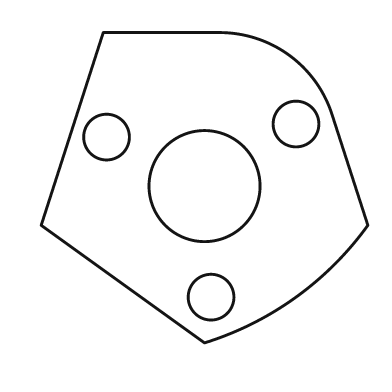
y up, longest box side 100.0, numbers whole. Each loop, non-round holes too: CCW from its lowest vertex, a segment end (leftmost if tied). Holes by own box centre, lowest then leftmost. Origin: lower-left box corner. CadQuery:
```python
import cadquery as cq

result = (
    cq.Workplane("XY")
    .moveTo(50.0, 0.0)
    .threePointArc((78.0, 14.0), (100.0, 36.0))
    .lineTo(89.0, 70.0)
    .threePointArc((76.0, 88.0), (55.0, 95.0))
    .lineTo(19.0, 95.0)
    .lineTo(0.0, 36.0)
    .close()
    .moveTo(52.0, 14.0)
    .circle(7.0)
    .moveTo(50.0, 48.0)
    .circle(17.0)
    .moveTo(20.0, 63.0)
    .circle(7.0)
    .moveTo(78.0, 67.0)
    .circle(7.0)
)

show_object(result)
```